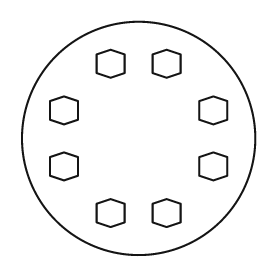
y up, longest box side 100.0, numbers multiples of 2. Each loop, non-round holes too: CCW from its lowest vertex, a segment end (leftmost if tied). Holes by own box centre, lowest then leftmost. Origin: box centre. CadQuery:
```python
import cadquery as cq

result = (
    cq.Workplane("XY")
    .moveTo(0.0, 0.0)
    .circle(50.0)
    .moveTo(-12.0, -38.0)
    .lineTo(-6.0, -36.0)
    .lineTo(-6.0, -28.0)
    .lineTo(-12.0, -26.0)
    .lineTo(-18.0, -28.0)
    .lineTo(-18.0, -36.0)
    .close()
    .moveTo(12.0, -38.0)
    .lineTo(18.0, -36.0)
    .lineTo(18.0, -28.0)
    .lineTo(12.0, -26.0)
    .lineTo(6.0, -28.0)
    .lineTo(6.0, -36.0)
    .close()
    .moveTo(-32.0, -18.0)
    .lineTo(-26.0, -16.0)
    .lineTo(-26.0, -8.0)
    .lineTo(-32.0, -6.0)
    .lineTo(-38.0, -8.0)
    .lineTo(-38.0, -16.0)
    .close()
    .moveTo(32.0, -18.0)
    .lineTo(38.0, -16.0)
    .lineTo(38.0, -8.0)
    .lineTo(32.0, -6.0)
    .lineTo(26.0, -8.0)
    .lineTo(26.0, -16.0)
    .close()
    .moveTo(-32.0, 6.0)
    .lineTo(-26.0, 8.0)
    .lineTo(-26.0, 16.0)
    .lineTo(-32.0, 18.0)
    .lineTo(-38.0, 16.0)
    .lineTo(-38.0, 8.0)
    .close()
    .moveTo(32.0, 6.0)
    .lineTo(38.0, 8.0)
    .lineTo(38.0, 16.0)
    .lineTo(32.0, 18.0)
    .lineTo(26.0, 16.0)
    .lineTo(26.0, 8.0)
    .close()
    .moveTo(-12.0, 26.0)
    .lineTo(-6.0, 28.0)
    .lineTo(-6.0, 36.0)
    .lineTo(-12.0, 38.0)
    .lineTo(-18.0, 36.0)
    .lineTo(-18.0, 28.0)
    .close()
    .moveTo(12.0, 26.0)
    .lineTo(18.0, 28.0)
    .lineTo(18.0, 36.0)
    .lineTo(12.0, 38.0)
    .lineTo(6.0, 36.0)
    .lineTo(6.0, 28.0)
    .close()
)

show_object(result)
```